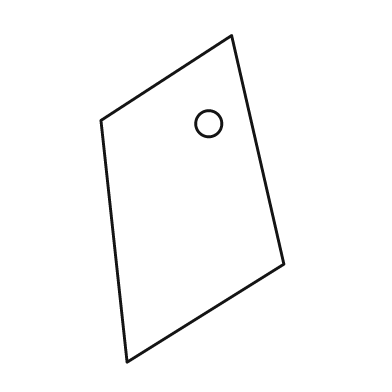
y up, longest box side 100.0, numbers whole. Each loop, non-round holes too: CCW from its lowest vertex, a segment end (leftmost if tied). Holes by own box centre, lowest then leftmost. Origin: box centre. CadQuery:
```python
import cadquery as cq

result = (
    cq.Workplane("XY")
    .moveTo(-20.0, -50.0)
    .lineTo(28.0, -20.0)
    .lineTo(12.0, 50.0)
    .lineTo(-28.0, 24.0)
    .close()
    .moveTo(5.0, 23.0)
    .circle(4.0)
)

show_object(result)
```